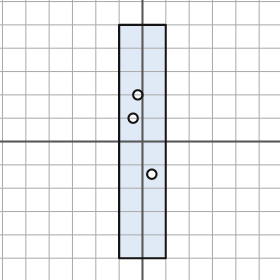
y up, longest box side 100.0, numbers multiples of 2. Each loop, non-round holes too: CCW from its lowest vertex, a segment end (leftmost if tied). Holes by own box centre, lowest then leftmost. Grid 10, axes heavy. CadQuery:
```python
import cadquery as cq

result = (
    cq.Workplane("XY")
    .moveTo(-10.0, -50.0)
    .lineTo(10.0, -50.0)
    .lineTo(10.0, 50.0)
    .lineTo(-10.0, 50.0)
    .close()
    .moveTo(4.0, -14.0)
    .circle(2.0)
    .moveTo(-4.0, 10.0)
    .circle(2.0)
    .moveTo(-2.0, 20.0)
    .circle(2.0)
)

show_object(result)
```